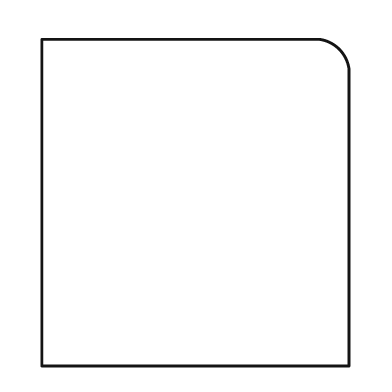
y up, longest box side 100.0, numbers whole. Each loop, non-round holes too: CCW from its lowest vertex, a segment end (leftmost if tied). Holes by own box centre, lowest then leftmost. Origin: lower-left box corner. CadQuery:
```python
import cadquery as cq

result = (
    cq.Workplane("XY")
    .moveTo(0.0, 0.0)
    .lineTo(94.0, 0.0)
    .lineTo(94.0, 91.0)
    .threePointArc((91.0, 97.0), (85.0, 100.0))
    .lineTo(0.0, 100.0)
    .close()
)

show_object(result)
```